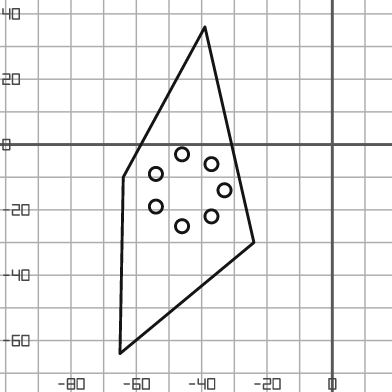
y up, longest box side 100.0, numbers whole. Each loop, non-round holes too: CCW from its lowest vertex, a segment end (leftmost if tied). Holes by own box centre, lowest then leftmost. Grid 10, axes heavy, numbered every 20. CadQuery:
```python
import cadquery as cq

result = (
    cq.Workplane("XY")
    .moveTo(-65.0, -64.0)
    .lineTo(-24.0, -30.0)
    .lineTo(-39.0, 36.0)
    .lineTo(-64.0, -10.0)
    .close()
    .moveTo(-46.0, -25.0)
    .circle(2.0)
    .moveTo(-37.0, -22.0)
    .circle(2.0)
    .moveTo(-54.0, -19.0)
    .circle(2.0)
    .moveTo(-33.0, -14.0)
    .circle(2.0)
    .moveTo(-54.0, -9.0)
    .circle(2.0)
    .moveTo(-37.0, -6.0)
    .circle(2.0)
    .moveTo(-46.0, -3.0)
    .circle(2.0)
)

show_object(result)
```